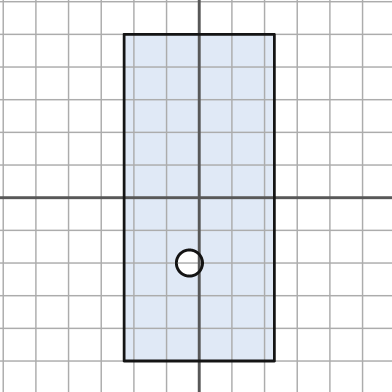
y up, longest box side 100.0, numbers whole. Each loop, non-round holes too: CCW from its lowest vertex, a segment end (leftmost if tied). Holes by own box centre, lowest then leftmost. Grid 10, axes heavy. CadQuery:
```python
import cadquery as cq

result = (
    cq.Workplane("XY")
    .moveTo(-23.0, -50.0)
    .lineTo(23.0, -50.0)
    .lineTo(23.0, 50.0)
    .lineTo(-23.0, 50.0)
    .close()
    .moveTo(-3.0, -20.0)
    .circle(4.0)
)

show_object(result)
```